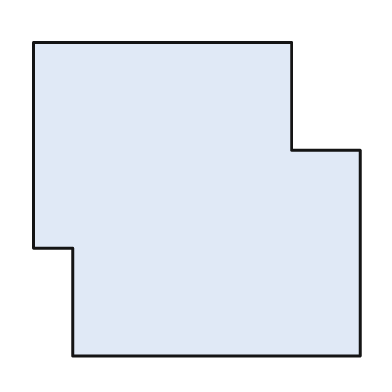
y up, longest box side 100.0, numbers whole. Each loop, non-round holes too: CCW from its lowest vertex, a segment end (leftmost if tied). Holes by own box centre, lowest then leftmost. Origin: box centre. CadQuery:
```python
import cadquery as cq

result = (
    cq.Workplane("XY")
    .moveTo(-38.0, -48.0)
    .lineTo(50.0, -48.0)
    .lineTo(50.0, 15.0)
    .lineTo(29.0, 15.0)
    .lineTo(29.0, 48.0)
    .lineTo(-50.0, 48.0)
    .lineTo(-50.0, -15.0)
    .lineTo(-38.0, -15.0)
    .close()
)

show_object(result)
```